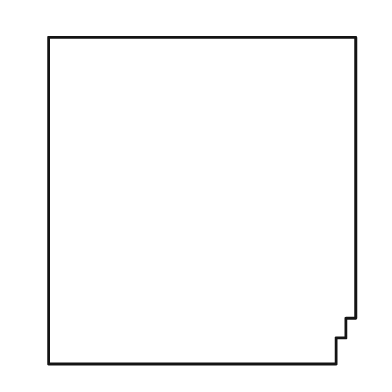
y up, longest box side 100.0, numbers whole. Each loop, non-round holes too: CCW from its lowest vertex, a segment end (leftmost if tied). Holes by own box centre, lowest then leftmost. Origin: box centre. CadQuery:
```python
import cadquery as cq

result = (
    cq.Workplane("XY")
    .moveTo(-47.0, -50.0)
    .lineTo(41.0, -50.0)
    .lineTo(41.0, -42.0)
    .lineTo(44.0, -42.0)
    .lineTo(44.0, -36.0)
    .lineTo(47.0, -36.0)
    .lineTo(47.0, 50.0)
    .lineTo(-47.0, 50.0)
    .close()
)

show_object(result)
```